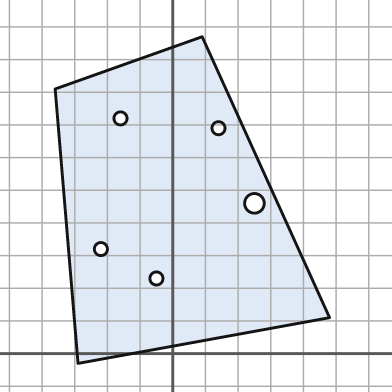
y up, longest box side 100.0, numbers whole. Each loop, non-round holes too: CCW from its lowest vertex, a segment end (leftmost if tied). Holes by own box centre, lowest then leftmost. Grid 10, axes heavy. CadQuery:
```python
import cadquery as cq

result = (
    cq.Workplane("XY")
    .moveTo(-29.0, -3.0)
    .lineTo(48.0, 11.0)
    .lineTo(9.0, 97.0)
    .lineTo(-36.0, 81.0)
    .close()
    .moveTo(-5.0, 23.0)
    .circle(2.0)
    .moveTo(-22.0, 32.0)
    .circle(2.0)
    .moveTo(25.0, 46.0)
    .circle(3.0)
    .moveTo(14.0, 69.0)
    .circle(2.0)
    .moveTo(-16.0, 72.0)
    .circle(2.0)
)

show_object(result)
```